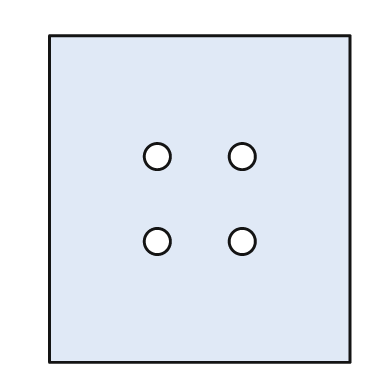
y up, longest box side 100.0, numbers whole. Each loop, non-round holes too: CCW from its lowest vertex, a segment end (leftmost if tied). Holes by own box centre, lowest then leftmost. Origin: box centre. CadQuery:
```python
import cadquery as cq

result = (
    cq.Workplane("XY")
    .moveTo(-46.0, -50.0)
    .lineTo(46.0, -50.0)
    .lineTo(46.0, 50.0)
    .lineTo(-46.0, 50.0)
    .close()
    .moveTo(-13.0, -13.0)
    .circle(4.0)
    .moveTo(13.0, -13.0)
    .circle(4.0)
    .moveTo(-13.0, 13.0)
    .circle(4.0)
    .moveTo(13.0, 13.0)
    .circle(4.0)
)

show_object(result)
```